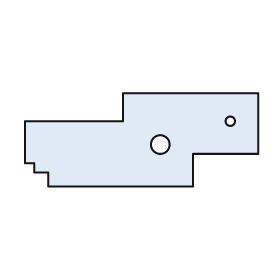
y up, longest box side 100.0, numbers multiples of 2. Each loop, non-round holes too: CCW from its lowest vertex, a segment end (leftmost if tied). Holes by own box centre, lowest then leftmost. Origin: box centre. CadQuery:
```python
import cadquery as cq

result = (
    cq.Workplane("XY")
    .moveTo(-40.0, -20.0)
    .lineTo(22.0, -20.0)
    .lineTo(22.0, -6.0)
    .lineTo(50.0, -6.0)
    .lineTo(50.0, 20.0)
    .lineTo(-8.0, 20.0)
    .lineTo(-8.0, 8.0)
    .lineTo(-50.0, 8.0)
    .lineTo(-50.0, -10.0)
    .lineTo(-46.0, -10.0)
    .lineTo(-46.0, -14.0)
    .lineTo(-40.0, -14.0)
    .close()
    .moveTo(8.0, -2.0)
    .circle(4.0)
    .moveTo(38.0, 8.0)
    .circle(2.0)
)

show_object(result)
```